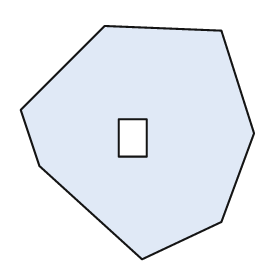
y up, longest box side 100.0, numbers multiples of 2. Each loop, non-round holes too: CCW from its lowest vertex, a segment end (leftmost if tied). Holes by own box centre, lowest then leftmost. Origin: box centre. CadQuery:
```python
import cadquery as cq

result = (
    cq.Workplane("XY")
    .moveTo(2.0, -50.0)
    .lineTo(36.0, -34.0)
    .lineTo(50.0, 4.0)
    .lineTo(36.0, 48.0)
    .lineTo(-14.0, 50.0)
    .lineTo(-50.0, 14.0)
    .lineTo(-42.0, -10.0)
    .close()
    .moveTo(-8.0, -6.0)
    .lineTo(4.0, -6.0)
    .lineTo(4.0, 10.0)
    .lineTo(-8.0, 10.0)
    .close()
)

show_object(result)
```